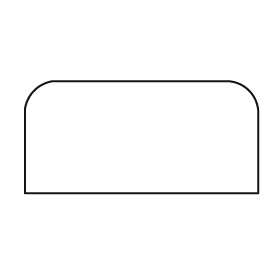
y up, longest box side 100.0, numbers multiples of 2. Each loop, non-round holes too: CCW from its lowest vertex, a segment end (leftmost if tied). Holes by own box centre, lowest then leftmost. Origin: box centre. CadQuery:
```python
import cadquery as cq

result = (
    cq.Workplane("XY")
    .moveTo(-50.0, -24.0)
    .lineTo(50.0, -24.0)
    .lineTo(50.0, 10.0)
    .threePointArc((46.0, 20.0), (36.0, 24.0))
    .lineTo(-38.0, 24.0)
    .threePointArc((-46.0, 20.0), (-50.0, 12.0))
    .close()
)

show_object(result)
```